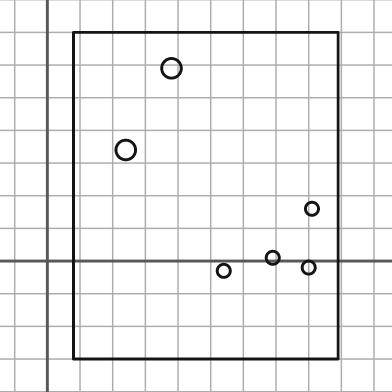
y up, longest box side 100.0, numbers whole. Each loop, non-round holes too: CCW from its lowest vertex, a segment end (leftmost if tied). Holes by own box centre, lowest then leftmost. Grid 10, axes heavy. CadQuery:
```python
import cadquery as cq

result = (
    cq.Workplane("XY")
    .moveTo(8.0, -30.0)
    .lineTo(89.0, -30.0)
    .lineTo(89.0, 70.0)
    .lineTo(8.0, 70.0)
    .close()
    .moveTo(54.0, -3.0)
    .circle(2.0)
    .moveTo(80.0, -2.0)
    .circle(2.0)
    .moveTo(69.0, 1.0)
    .circle(2.0)
    .moveTo(81.0, 16.0)
    .circle(2.0)
    .moveTo(24.0, 34.0)
    .circle(3.0)
    .moveTo(38.0, 59.0)
    .circle(3.0)
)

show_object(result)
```